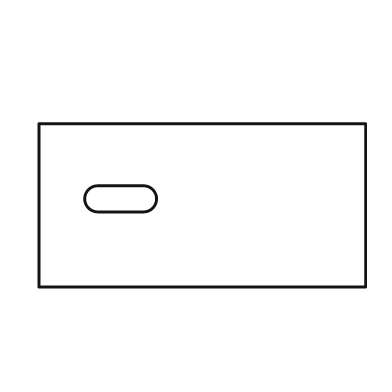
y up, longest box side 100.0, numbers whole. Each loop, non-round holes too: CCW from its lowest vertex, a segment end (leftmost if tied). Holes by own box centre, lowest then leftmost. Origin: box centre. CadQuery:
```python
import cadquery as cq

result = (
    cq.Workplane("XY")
    .moveTo(-50.0, -25.0)
    .lineTo(50.0, -25.0)
    .lineTo(50.0, 25.0)
    .lineTo(-50.0, 25.0)
    .close()
    .moveTo(-32.0, -2.0)
    .lineTo(-18.0, -2.0)
    .threePointArc((-14.0, 2.0), (-18.0, 6.0))
    .lineTo(-32.0, 6.0)
    .threePointArc((-36.0, 2.0), (-32.0, -2.0))
    .close()
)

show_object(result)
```